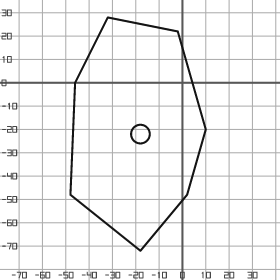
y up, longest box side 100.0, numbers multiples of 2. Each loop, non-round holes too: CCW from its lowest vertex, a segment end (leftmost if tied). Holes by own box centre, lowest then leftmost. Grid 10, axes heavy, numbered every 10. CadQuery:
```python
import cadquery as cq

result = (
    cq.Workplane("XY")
    .moveTo(-18.0, -72.0)
    .lineTo(2.0, -48.0)
    .lineTo(10.0, -20.0)
    .lineTo(-2.0, 22.0)
    .lineTo(-32.0, 28.0)
    .lineTo(-46.0, 0.0)
    .lineTo(-48.0, -48.0)
    .close()
    .moveTo(-18.0, -22.0)
    .circle(4.0)
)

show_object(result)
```